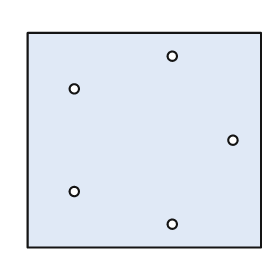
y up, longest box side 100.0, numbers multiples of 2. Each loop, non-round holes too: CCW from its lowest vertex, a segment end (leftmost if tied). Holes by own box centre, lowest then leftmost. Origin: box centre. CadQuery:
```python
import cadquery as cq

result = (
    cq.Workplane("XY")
    .moveTo(-50.0, -46.0)
    .lineTo(50.0, -46.0)
    .lineTo(50.0, 46.0)
    .lineTo(-50.0, 46.0)
    .close()
    .moveTo(12.0, -36.0)
    .circle(2.0)
    .moveTo(-30.0, -22.0)
    .circle(2.0)
    .moveTo(38.0, 0.0)
    .circle(2.0)
    .moveTo(-30.0, 22.0)
    .circle(2.0)
    .moveTo(12.0, 36.0)
    .circle(2.0)
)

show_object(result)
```